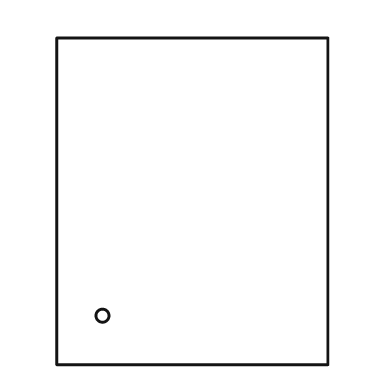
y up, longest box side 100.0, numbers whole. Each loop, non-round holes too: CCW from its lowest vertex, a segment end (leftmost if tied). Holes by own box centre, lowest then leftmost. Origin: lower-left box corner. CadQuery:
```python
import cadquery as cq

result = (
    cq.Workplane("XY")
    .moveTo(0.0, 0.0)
    .lineTo(83.0, 0.0)
    .lineTo(83.0, 100.0)
    .lineTo(0.0, 100.0)
    .close()
    .moveTo(14.0, 15.0)
    .circle(2.0)
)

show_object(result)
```